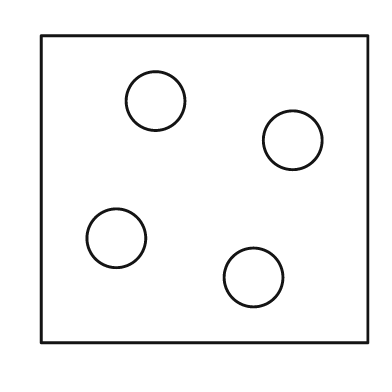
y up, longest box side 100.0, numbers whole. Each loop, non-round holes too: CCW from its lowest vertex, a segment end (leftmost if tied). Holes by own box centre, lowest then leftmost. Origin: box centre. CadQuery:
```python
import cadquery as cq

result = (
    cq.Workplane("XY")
    .moveTo(-50.0, -47.0)
    .lineTo(50.0, -47.0)
    .lineTo(50.0, 47.0)
    .lineTo(-50.0, 47.0)
    .close()
    .moveTo(15.0, -27.0)
    .circle(9.0)
    .moveTo(-27.0, -15.0)
    .circle(9.0)
    .moveTo(27.0, 15.0)
    .circle(9.0)
    .moveTo(-15.0, 27.0)
    .circle(9.0)
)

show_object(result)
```